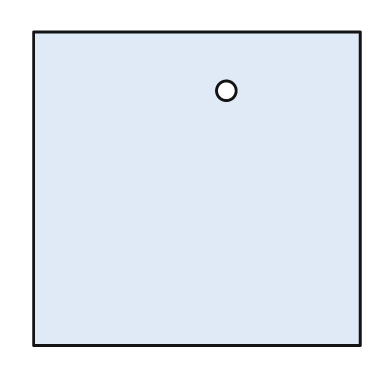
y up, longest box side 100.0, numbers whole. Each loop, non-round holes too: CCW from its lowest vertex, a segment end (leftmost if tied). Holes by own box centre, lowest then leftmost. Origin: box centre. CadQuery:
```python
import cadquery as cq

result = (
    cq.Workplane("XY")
    .moveTo(-50.0, -48.0)
    .lineTo(50.0, -48.0)
    .lineTo(50.0, 48.0)
    .lineTo(-50.0, 48.0)
    .close()
    .moveTo(9.0, 30.0)
    .circle(3.0)
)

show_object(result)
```